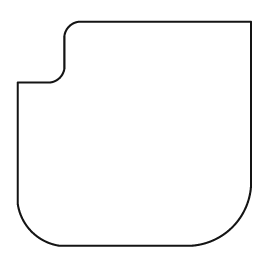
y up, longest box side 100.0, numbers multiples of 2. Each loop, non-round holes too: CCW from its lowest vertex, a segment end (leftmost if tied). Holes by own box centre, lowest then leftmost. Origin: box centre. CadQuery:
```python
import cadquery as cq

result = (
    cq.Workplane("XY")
    .moveTo(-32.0, -48.0)
    .lineTo(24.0, -48.0)
    .threePointArc((42.0, -40.0), (50.0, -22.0))
    .lineTo(50.0, 48.0)
    .lineTo(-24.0, 48.0)
    .threePointArc((-28.0, 46.0), (-30.0, 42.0))
    .lineTo(-30.0, 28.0)
    .threePointArc((-32.0, 24.0), (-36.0, 22.0))
    .lineTo(-50.0, 22.0)
    .lineTo(-50.0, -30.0)
    .threePointArc((-44.0, -42.0), (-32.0, -48.0))
    .close()
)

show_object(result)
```